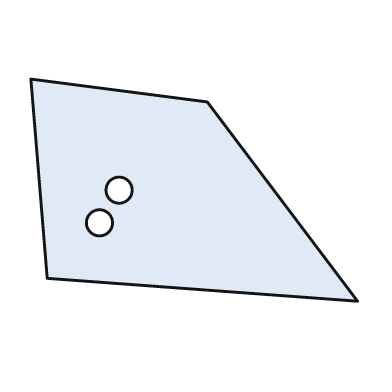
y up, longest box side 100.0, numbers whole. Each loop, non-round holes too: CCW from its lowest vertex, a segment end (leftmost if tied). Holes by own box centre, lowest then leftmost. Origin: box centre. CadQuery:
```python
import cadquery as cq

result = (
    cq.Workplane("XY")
    .moveTo(50.0, -34.0)
    .lineTo(4.0, 27.0)
    .lineTo(-50.0, 34.0)
    .lineTo(-45.0, -27.0)
    .close()
    .moveTo(-29.0, -10.0)
    .circle(4.0)
    .moveTo(-23.0, 0.0)
    .circle(4.0)
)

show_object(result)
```